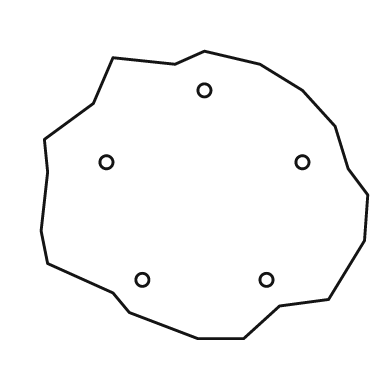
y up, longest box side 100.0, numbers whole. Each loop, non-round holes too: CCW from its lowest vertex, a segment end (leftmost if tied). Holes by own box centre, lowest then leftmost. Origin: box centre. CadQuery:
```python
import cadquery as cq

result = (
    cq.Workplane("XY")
    .moveTo(-2.0, -44.0)
    .lineTo(12.0, -44.0)
    .lineTo(23.0, -34.0)
    .lineTo(38.0, -32.0)
    .lineTo(49.0, -14.0)
    .lineTo(50.0, 0.0)
    .lineTo(44.0, 8.0)
    .lineTo(40.0, 21.0)
    .lineTo(30.0, 32.0)
    .lineTo(17.0, 40.0)
    .lineTo(0.0, 44.0)
    .lineTo(-9.0, 40.0)
    .lineTo(-28.0, 42.0)
    .lineTo(-34.0, 28.0)
    .lineTo(-49.0, 17.0)
    .lineTo(-48.0, 7.0)
    .lineTo(-50.0, -11.0)
    .lineTo(-48.0, -21.0)
    .lineTo(-28.0, -30.0)
    .lineTo(-23.0, -36.0)
    .close()
    .moveTo(-19.0, -26.0)
    .circle(2.0)
    .moveTo(19.0, -26.0)
    .circle(2.0)
    .moveTo(-30.0, 10.0)
    .circle(2.0)
    .moveTo(30.0, 10.0)
    .circle(2.0)
    .moveTo(0.0, 32.0)
    .circle(2.0)
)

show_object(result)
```